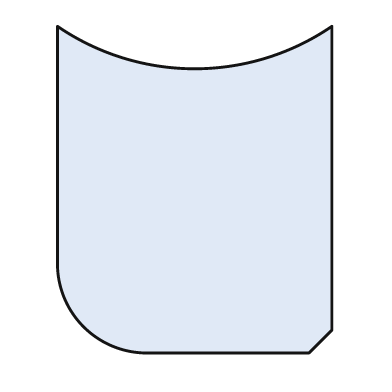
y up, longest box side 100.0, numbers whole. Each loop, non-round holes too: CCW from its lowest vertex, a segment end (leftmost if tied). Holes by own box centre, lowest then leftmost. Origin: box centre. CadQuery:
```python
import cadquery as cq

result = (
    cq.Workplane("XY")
    .moveTo(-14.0, -50.0)
    .lineTo(35.0, -50.0)
    .lineTo(42.0, -43.0)
    .lineTo(42.0, 50.0)
    .threePointArc((0.0, 37.0), (-42.0, 50.0))
    .lineTo(-42.0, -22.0)
    .threePointArc((-34.0, -42.0), (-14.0, -50.0))
    .close()
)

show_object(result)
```